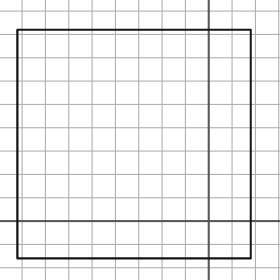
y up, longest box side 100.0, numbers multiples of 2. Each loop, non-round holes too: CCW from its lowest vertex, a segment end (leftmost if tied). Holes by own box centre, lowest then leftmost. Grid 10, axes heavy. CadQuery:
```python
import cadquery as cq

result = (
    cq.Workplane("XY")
    .moveTo(-82.0, -16.0)
    .lineTo(18.0, -16.0)
    .lineTo(18.0, 82.0)
    .lineTo(-82.0, 82.0)
    .close()
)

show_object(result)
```